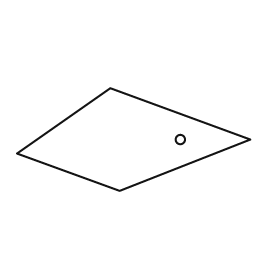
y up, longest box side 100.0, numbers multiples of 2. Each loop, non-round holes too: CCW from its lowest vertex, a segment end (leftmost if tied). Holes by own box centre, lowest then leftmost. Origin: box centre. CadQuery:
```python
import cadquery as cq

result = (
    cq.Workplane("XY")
    .moveTo(-6.0, -22.0)
    .lineTo(50.0, 0.0)
    .lineTo(-10.0, 22.0)
    .lineTo(-50.0, -6.0)
    .close()
    .moveTo(20.0, 0.0)
    .circle(2.0)
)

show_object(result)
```